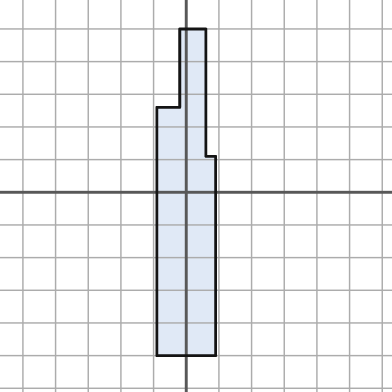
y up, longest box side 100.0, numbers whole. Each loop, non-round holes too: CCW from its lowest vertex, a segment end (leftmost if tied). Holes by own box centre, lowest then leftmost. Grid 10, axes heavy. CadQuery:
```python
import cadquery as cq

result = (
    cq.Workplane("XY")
    .moveTo(-9.0, -50.0)
    .lineTo(9.0, -50.0)
    .lineTo(9.0, 11.0)
    .lineTo(6.0, 11.0)
    .lineTo(6.0, 50.0)
    .lineTo(-2.0, 50.0)
    .lineTo(-2.0, 26.0)
    .lineTo(-9.0, 26.0)
    .close()
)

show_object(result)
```